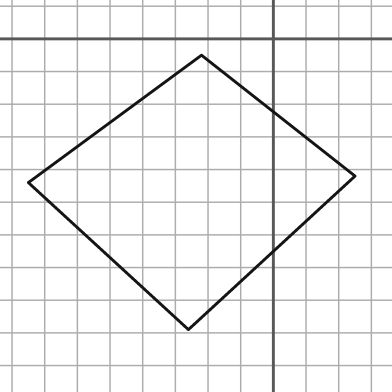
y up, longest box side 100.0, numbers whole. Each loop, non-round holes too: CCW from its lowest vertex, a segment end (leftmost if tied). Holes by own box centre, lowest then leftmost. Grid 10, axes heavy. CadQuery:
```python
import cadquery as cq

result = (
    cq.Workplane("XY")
    .moveTo(-26.0, -89.0)
    .lineTo(25.0, -42.0)
    .lineTo(-22.0, -5.0)
    .lineTo(-75.0, -44.0)
    .close()
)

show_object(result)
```